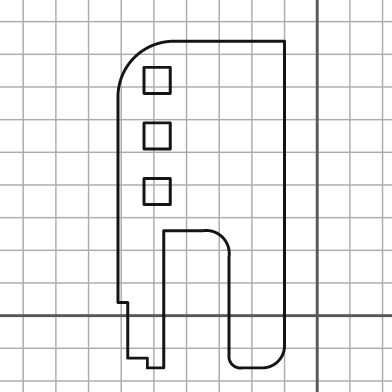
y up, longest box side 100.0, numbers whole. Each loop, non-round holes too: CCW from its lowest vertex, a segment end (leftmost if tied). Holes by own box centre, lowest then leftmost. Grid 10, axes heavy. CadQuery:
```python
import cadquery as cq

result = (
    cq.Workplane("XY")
    .moveTo(-52.0, -16.0)
    .lineTo(-47.0, -16.0)
    .lineTo(-47.0, 26.0)
    .lineTo(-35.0, 26.0)
    .threePointArc((-29.0, 24.0), (-27.0, 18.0))
    .lineTo(-27.0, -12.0)
    .threePointArc((-26.0, -15.0), (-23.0, -16.0))
    .lineTo(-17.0, -16.0)
    .threePointArc((-12.0, -14.0), (-10.0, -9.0))
    .lineTo(-10.0, 84.0)
    .lineTo(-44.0, 84.0)
    .threePointArc((-56.0, 79.0), (-61.0, 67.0))
    .lineTo(-61.0, 4.0)
    .lineTo(-58.0, 4.0)
    .lineTo(-58.0, -13.0)
    .lineTo(-52.0, -13.0)
    .close()
    .moveTo(-53.0, 34.0)
    .lineTo(-45.0, 34.0)
    .lineTo(-45.0, 42.0)
    .lineTo(-53.0, 42.0)
    .close()
    .moveTo(-53.0, 51.0)
    .lineTo(-45.0, 51.0)
    .lineTo(-45.0, 59.0)
    .lineTo(-53.0, 59.0)
    .close()
    .moveTo(-53.0, 68.0)
    .lineTo(-45.0, 68.0)
    .lineTo(-45.0, 76.0)
    .lineTo(-53.0, 76.0)
    .close()
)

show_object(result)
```